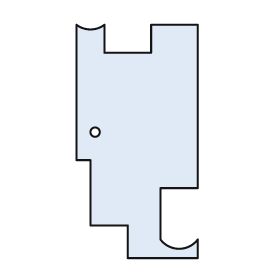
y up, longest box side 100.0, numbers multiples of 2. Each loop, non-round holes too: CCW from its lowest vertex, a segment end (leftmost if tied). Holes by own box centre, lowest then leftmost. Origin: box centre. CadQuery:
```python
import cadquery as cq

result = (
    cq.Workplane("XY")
    .moveTo(-4.0, -50.0)
    .lineTo(26.0, -50.0)
    .lineTo(26.0, -42.0)
    .threePointArc((18.0, -46.0), (10.0, -42.0))
    .lineTo(10.0, -20.0)
    .lineTo(26.0, -20.0)
    .lineTo(26.0, 50.0)
    .lineTo(6.0, 50.0)
    .lineTo(6.0, 38.0)
    .lineTo(-14.0, 38.0)
    .lineTo(-14.0, 50.0)
    .threePointArc((-20.0, 48.0), (-26.0, 50.0))
    .lineTo(-26.0, -8.0)
    .lineTo(-20.0, -8.0)
    .lineTo(-20.0, -36.0)
    .lineTo(-4.0, -36.0)
    .close()
    .moveTo(-18.0, 4.0)
    .circle(2.0)
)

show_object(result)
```